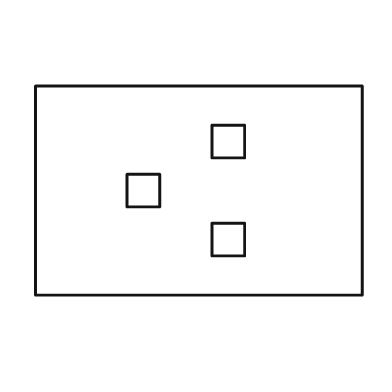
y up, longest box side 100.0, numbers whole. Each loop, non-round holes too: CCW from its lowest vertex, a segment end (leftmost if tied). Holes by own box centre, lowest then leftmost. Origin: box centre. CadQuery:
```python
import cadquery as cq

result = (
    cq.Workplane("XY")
    .moveTo(-50.0, -32.0)
    .lineTo(50.0, -32.0)
    .lineTo(50.0, 32.0)
    .lineTo(-50.0, 32.0)
    .close()
    .moveTo(4.0, -20.0)
    .lineTo(14.0, -20.0)
    .lineTo(14.0, -10.0)
    .lineTo(4.0, -10.0)
    .close()
    .moveTo(-22.0, -5.0)
    .lineTo(-12.0, -5.0)
    .lineTo(-12.0, 5.0)
    .lineTo(-22.0, 5.0)
    .close()
    .moveTo(4.0, 10.0)
    .lineTo(14.0, 10.0)
    .lineTo(14.0, 20.0)
    .lineTo(4.0, 20.0)
    .close()
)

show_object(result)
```